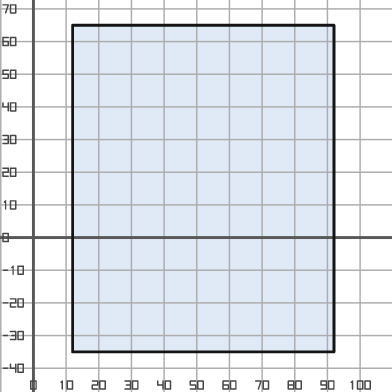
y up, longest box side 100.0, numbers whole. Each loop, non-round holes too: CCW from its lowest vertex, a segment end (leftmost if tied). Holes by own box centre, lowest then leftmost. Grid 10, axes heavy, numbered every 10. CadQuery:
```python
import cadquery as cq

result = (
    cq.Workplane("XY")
    .moveTo(12.0, -35.0)
    .lineTo(92.0, -35.0)
    .lineTo(92.0, 65.0)
    .lineTo(12.0, 65.0)
    .close()
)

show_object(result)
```